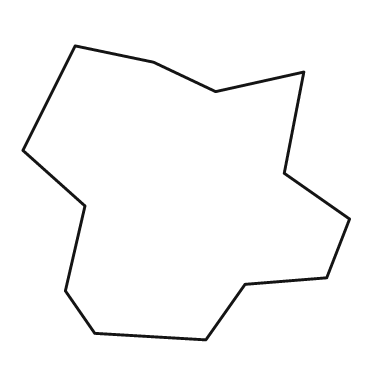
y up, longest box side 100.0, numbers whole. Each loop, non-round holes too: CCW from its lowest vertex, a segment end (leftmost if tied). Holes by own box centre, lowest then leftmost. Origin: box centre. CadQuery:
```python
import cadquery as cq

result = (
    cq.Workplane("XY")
    .moveTo(6.0, -45.0)
    .lineTo(18.0, -28.0)
    .lineTo(43.0, -26.0)
    .lineTo(50.0, -8.0)
    .lineTo(30.0, 6.0)
    .lineTo(36.0, 37.0)
    .lineTo(9.0, 31.0)
    .lineTo(-10.0, 40.0)
    .lineTo(-34.0, 45.0)
    .lineTo(-50.0, 13.0)
    .lineTo(-31.0, -4.0)
    .lineTo(-37.0, -30.0)
    .lineTo(-28.0, -43.0)
    .close()
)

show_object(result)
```